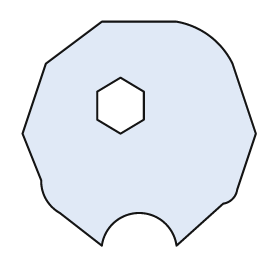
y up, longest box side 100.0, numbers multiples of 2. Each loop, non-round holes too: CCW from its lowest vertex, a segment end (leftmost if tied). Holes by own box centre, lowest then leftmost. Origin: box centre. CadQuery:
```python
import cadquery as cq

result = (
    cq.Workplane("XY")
    .moveTo(-16.0, -48.0)
    .threePointArc((0.0, -34.0), (16.0, -48.0))
    .lineTo(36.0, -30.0)
    .threePointArc((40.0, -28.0), (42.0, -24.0))
    .lineTo(50.0, 0.0)
    .lineTo(40.0, 30.0)
    .threePointArc((30.0, 42.0), (16.0, 48.0))
    .lineTo(-16.0, 48.0)
    .lineTo(-40.0, 30.0)
    .lineTo(-50.0, 0.0)
    .lineTo(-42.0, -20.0)
    .threePointArc((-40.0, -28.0), (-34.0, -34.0))
    .close()
    .moveTo(-8.0, 0.0)
    .lineTo(2.0, 6.0)
    .lineTo(2.0, 18.0)
    .lineTo(-8.0, 24.0)
    .lineTo(-18.0, 18.0)
    .lineTo(-18.0, 6.0)
    .close()
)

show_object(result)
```